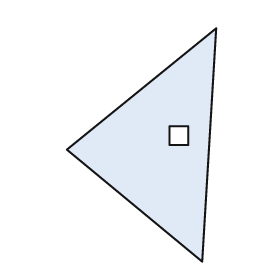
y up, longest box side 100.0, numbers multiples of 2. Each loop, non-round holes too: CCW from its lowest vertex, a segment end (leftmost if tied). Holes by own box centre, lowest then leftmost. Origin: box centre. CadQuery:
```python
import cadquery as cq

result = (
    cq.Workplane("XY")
    .moveTo(26.0, -50.0)
    .lineTo(32.0, 50.0)
    .lineTo(-32.0, -2.0)
    .close()
    .moveTo(12.0, 0.0)
    .lineTo(20.0, 0.0)
    .lineTo(20.0, 8.0)
    .lineTo(12.0, 8.0)
    .close()
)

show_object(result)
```